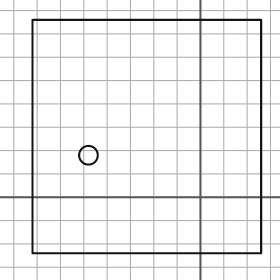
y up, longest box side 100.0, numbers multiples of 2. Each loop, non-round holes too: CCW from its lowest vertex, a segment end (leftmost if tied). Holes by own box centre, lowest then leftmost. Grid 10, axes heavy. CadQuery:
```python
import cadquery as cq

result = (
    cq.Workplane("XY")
    .moveTo(-72.0, -24.0)
    .lineTo(26.0, -24.0)
    .lineTo(26.0, 76.0)
    .lineTo(-72.0, 76.0)
    .close()
    .moveTo(-48.0, 18.0)
    .circle(4.0)
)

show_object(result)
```